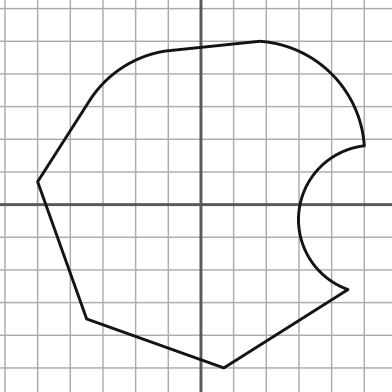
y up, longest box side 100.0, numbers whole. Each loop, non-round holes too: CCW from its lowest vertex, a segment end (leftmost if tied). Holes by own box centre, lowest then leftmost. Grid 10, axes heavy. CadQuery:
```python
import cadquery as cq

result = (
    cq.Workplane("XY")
    .moveTo(7.0, -50.0)
    .lineTo(45.0, -26.0)
    .threePointArc((30.0, -2.0), (50.0, 18.0))
    .threePointArc((40.0, 40.0), (18.0, 50.0))
    .lineTo(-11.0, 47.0)
    .threePointArc((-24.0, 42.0), (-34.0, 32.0))
    .lineTo(-50.0, 7.0)
    .lineTo(-35.0, -35.0)
    .close()
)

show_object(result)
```